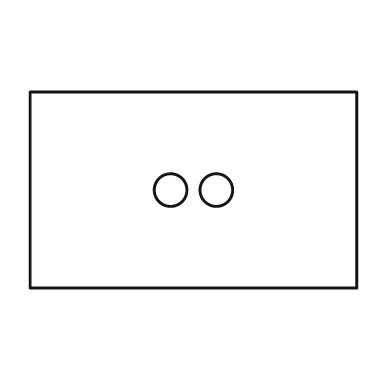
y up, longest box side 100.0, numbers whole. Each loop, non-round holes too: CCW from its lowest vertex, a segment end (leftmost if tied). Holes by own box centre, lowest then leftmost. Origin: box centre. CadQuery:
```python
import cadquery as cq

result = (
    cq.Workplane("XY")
    .moveTo(-50.0, -30.0)
    .lineTo(50.0, -30.0)
    .lineTo(50.0, 30.0)
    .lineTo(-50.0, 30.0)
    .close()
    .moveTo(-7.0, 0.0)
    .circle(5.0)
    .moveTo(7.0, 0.0)
    .circle(5.0)
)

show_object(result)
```